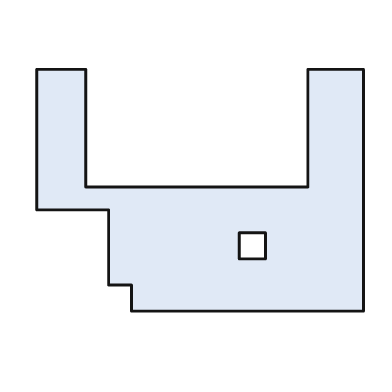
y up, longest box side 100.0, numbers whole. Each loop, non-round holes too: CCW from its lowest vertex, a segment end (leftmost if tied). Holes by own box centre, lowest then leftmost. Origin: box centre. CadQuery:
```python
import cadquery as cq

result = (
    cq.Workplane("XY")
    .moveTo(-21.0, -37.0)
    .lineTo(50.0, -37.0)
    .lineTo(50.0, 37.0)
    .lineTo(33.0, 37.0)
    .lineTo(33.0, 1.0)
    .lineTo(-35.0, 1.0)
    .lineTo(-35.0, 37.0)
    .lineTo(-50.0, 37.0)
    .lineTo(-50.0, -6.0)
    .lineTo(-28.0, -6.0)
    .lineTo(-28.0, -29.0)
    .lineTo(-21.0, -29.0)
    .close()
    .moveTo(12.0, -21.0)
    .lineTo(20.0, -21.0)
    .lineTo(20.0, -13.0)
    .lineTo(12.0, -13.0)
    .close()
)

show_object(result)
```